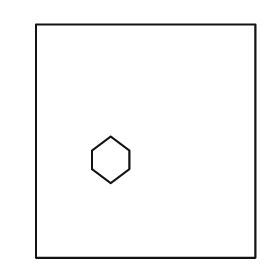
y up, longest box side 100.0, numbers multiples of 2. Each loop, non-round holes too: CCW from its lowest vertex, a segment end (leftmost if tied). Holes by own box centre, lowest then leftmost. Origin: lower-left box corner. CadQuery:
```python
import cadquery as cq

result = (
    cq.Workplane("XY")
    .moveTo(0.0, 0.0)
    .lineTo(94.0, 0.0)
    .lineTo(94.0, 100.0)
    .lineTo(0.0, 100.0)
    .close()
    .moveTo(32.0, 32.0)
    .lineTo(40.0, 38.0)
    .lineTo(40.0, 46.0)
    .lineTo(32.0, 52.0)
    .lineTo(24.0, 46.0)
    .lineTo(24.0, 38.0)
    .close()
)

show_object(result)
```